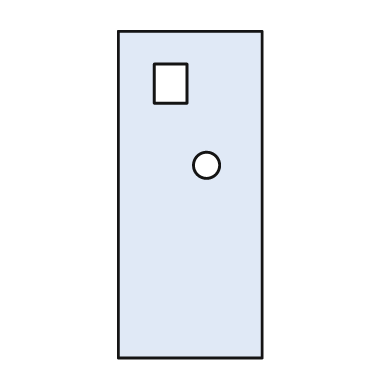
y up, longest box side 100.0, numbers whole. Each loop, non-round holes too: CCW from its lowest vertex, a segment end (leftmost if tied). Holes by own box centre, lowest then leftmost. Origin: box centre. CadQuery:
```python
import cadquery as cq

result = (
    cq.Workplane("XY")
    .moveTo(-22.0, -50.0)
    .lineTo(22.0, -50.0)
    .lineTo(22.0, 50.0)
    .lineTo(-22.0, 50.0)
    .close()
    .moveTo(5.0, 9.0)
    .circle(4.0)
    .moveTo(-11.0, 28.0)
    .lineTo(-1.0, 28.0)
    .lineTo(-1.0, 40.0)
    .lineTo(-11.0, 40.0)
    .close()
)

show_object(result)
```